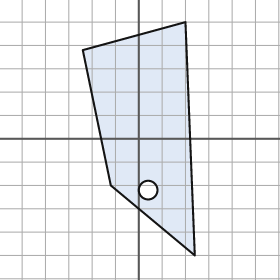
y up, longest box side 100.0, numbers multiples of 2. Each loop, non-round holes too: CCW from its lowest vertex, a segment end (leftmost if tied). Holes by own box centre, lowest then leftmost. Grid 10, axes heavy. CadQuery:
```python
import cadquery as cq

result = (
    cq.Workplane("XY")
    .moveTo(24.0, -50.0)
    .lineTo(20.0, 50.0)
    .lineTo(-24.0, 38.0)
    .lineTo(-12.0, -20.0)
    .close()
    .moveTo(4.0, -22.0)
    .circle(4.0)
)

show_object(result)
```